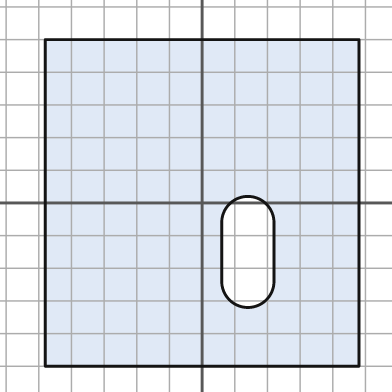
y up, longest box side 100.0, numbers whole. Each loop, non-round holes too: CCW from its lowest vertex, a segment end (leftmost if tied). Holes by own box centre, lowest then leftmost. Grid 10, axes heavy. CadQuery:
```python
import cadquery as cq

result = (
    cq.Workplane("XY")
    .moveTo(-48.0, -50.0)
    .lineTo(48.0, -50.0)
    .lineTo(48.0, 50.0)
    .lineTo(-48.0, 50.0)
    .close()
    .moveTo(6.0, -24.0)
    .threePointArc((14.0, -32.0), (22.0, -24.0))
    .lineTo(22.0, -6.0)
    .threePointArc((14.0, 2.0), (6.0, -6.0))
    .close()
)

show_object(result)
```